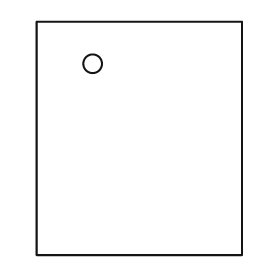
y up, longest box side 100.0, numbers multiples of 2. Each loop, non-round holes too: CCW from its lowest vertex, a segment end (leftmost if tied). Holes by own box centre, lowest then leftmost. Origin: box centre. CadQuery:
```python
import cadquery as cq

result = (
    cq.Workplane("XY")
    .moveTo(-44.0, -50.0)
    .lineTo(44.0, -50.0)
    .lineTo(44.0, 50.0)
    .lineTo(-44.0, 50.0)
    .close()
    .moveTo(-20.0, 32.0)
    .circle(4.0)
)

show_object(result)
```